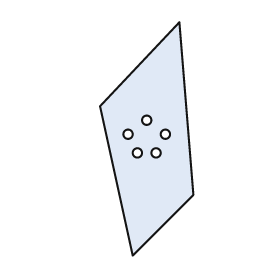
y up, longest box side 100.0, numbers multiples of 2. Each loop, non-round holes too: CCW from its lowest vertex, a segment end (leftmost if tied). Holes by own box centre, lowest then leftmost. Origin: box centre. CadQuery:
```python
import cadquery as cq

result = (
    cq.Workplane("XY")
    .moveTo(-6.0, -50.0)
    .lineTo(20.0, -24.0)
    .lineTo(14.0, 50.0)
    .lineTo(-20.0, 14.0)
    .close()
    .moveTo(-4.0, -6.0)
    .circle(2.0)
    .moveTo(4.0, -6.0)
    .circle(2.0)
    .moveTo(-8.0, 2.0)
    .circle(2.0)
    .moveTo(8.0, 2.0)
    .circle(2.0)
    .moveTo(0.0, 8.0)
    .circle(2.0)
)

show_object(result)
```